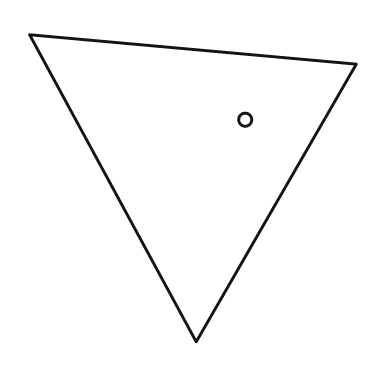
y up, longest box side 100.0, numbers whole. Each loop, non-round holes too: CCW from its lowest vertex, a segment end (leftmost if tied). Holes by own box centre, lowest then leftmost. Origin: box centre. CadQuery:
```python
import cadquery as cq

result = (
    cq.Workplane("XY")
    .moveTo(1.0, -47.0)
    .lineTo(50.0, 38.0)
    .lineTo(-50.0, 47.0)
    .close()
    .moveTo(16.0, 21.0)
    .circle(2.0)
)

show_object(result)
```